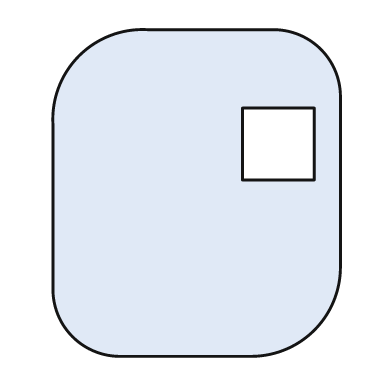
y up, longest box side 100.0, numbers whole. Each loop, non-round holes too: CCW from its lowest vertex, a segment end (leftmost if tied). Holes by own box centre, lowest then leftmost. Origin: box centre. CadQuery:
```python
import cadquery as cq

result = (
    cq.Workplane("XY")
    .moveTo(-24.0, -50.0)
    .lineTo(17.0, -50.0)
    .threePointArc((36.0, -42.0), (44.0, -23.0))
    .lineTo(44.0, 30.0)
    .threePointArc((38.0, 44.0), (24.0, 50.0))
    .lineTo(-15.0, 50.0)
    .threePointArc((-36.0, 42.0), (-44.0, 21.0))
    .lineTo(-44.0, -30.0)
    .threePointArc((-38.0, -44.0), (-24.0, -50.0))
    .close()
    .moveTo(14.0, 4.0)
    .lineTo(36.0, 4.0)
    .lineTo(36.0, 26.0)
    .lineTo(14.0, 26.0)
    .close()
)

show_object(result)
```